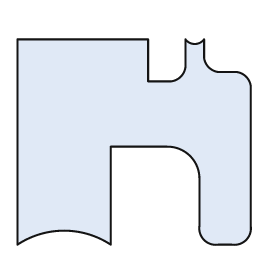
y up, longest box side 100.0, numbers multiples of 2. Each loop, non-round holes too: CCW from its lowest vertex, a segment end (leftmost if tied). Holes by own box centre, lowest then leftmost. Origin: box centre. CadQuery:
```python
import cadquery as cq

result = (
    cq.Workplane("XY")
    .moveTo(-50.0, -44.0)
    .threePointArc((-30.0, -38.0), (-10.0, -44.0))
    .lineTo(-10.0, -2.0)
    .lineTo(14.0, -2.0)
    .threePointArc((24.0, -6.0), (28.0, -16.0))
    .lineTo(28.0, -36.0)
    .threePointArc((30.0, -42.0), (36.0, -44.0))
    .lineTo(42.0, -44.0)
    .threePointArc((48.0, -42.0), (50.0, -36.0))
    .lineTo(50.0, 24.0)
    .threePointArc((48.0, 28.0), (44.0, 30.0))
    .lineTo(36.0, 30.0)
    .threePointArc((32.0, 32.0), (30.0, 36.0))
    .lineTo(30.0, 44.0)
    .threePointArc((26.0, 42.0), (22.0, 44.0))
    .lineTo(22.0, 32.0)
    .threePointArc((20.0, 28.0), (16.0, 26.0))
    .lineTo(6.0, 26.0)
    .lineTo(6.0, 44.0)
    .lineTo(-50.0, 44.0)
    .close()
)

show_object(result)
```